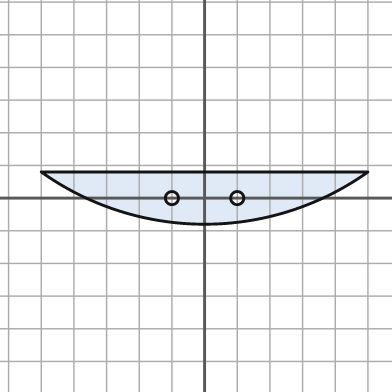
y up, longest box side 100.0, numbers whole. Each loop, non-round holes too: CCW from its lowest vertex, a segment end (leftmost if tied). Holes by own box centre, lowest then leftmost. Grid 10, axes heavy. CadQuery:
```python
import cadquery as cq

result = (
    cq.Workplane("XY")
    .moveTo(-50.0, 8.0)
    .threePointArc((0.0, -8.0), (50.0, 8.0))
    .close()
    .moveTo(-10.0, 0.0)
    .circle(2.0)
    .moveTo(10.0, 0.0)
    .circle(2.0)
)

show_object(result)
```